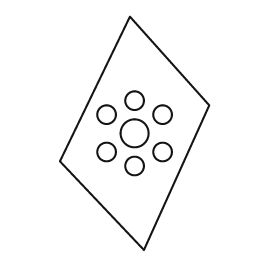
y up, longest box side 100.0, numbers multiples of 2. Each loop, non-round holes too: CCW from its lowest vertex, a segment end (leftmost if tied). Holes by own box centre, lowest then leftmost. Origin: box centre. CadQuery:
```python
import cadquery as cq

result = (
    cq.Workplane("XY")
    .moveTo(4.0, -50.0)
    .lineTo(32.0, 12.0)
    .lineTo(-2.0, 50.0)
    .lineTo(-32.0, -12.0)
    .close()
    .moveTo(0.0, -14.0)
    .circle(4.0)
    .moveTo(-12.0, -8.0)
    .circle(4.0)
    .moveTo(12.0, -8.0)
    .circle(4.0)
    .moveTo(0.0, 0.0)
    .circle(6.0)
    .moveTo(-12.0, 8.0)
    .circle(4.0)
    .moveTo(12.0, 8.0)
    .circle(4.0)
    .moveTo(0.0, 14.0)
    .circle(4.0)
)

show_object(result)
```